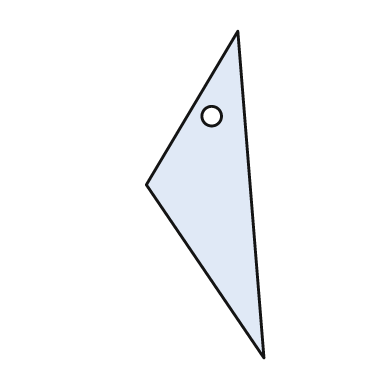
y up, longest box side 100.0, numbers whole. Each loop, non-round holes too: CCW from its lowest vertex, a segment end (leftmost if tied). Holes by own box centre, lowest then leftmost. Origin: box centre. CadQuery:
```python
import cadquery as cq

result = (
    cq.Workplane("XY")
    .moveTo(18.0, -50.0)
    .lineTo(10.0, 50.0)
    .lineTo(-18.0, 3.0)
    .close()
    .moveTo(2.0, 24.0)
    .circle(3.0)
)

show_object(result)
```